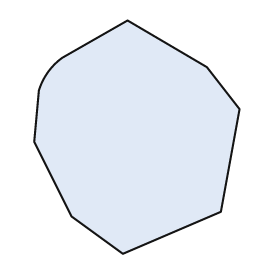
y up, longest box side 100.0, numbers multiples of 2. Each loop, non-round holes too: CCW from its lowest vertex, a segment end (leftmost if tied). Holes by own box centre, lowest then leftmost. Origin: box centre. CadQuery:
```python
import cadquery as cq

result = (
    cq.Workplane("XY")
    .moveTo(-6.0, -50.0)
    .lineTo(36.0, -32.0)
    .lineTo(44.0, 12.0)
    .lineTo(30.0, 30.0)
    .lineTo(-4.0, 50.0)
    .lineTo(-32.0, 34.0)
    .threePointArc((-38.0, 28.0), (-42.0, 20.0))
    .lineTo(-44.0, -2.0)
    .lineTo(-28.0, -34.0)
    .close()
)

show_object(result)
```